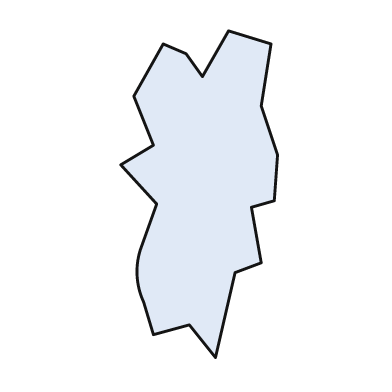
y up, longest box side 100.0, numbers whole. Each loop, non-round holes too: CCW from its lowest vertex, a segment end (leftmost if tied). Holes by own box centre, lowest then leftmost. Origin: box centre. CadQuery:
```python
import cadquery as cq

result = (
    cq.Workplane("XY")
    .moveTo(5.0, -50.0)
    .lineTo(11.0, -24.0)
    .lineTo(19.0, -21.0)
    .lineTo(16.0, -4.0)
    .lineTo(23.0, -2.0)
    .lineTo(24.0, 12.0)
    .lineTo(19.0, 27.0)
    .lineTo(22.0, 46.0)
    .lineTo(9.0, 50.0)
    .lineTo(1.0, 36.0)
    .lineTo(-4.0, 43.0)
    .lineTo(-11.0, 46.0)
    .lineTo(-20.0, 30.0)
    .lineTo(-14.0, 15.0)
    .lineTo(-24.0, 9.0)
    .lineTo(-13.0, -3.0)
    .lineTo(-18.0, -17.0)
    .threePointArc((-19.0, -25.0), (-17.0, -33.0))
    .lineTo(-14.0, -43.0)
    .lineTo(-3.0, -40.0)
    .close()
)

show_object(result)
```